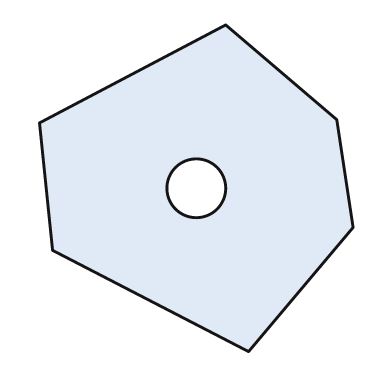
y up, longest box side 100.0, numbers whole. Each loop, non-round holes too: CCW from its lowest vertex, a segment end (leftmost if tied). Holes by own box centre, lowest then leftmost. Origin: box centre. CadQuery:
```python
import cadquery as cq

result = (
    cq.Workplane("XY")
    .moveTo(16.0, -50.0)
    .lineTo(48.0, -12.0)
    .lineTo(43.0, 21.0)
    .lineTo(9.0, 50.0)
    .lineTo(-48.0, 20.0)
    .lineTo(-44.0, -19.0)
    .close()
    .moveTo(0.0, 0.0)
    .circle(9.0)
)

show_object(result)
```